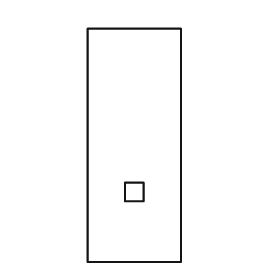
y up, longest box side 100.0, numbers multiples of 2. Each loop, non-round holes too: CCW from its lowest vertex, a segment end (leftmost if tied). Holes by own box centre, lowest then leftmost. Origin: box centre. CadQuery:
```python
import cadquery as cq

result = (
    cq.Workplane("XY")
    .moveTo(-20.0, -50.0)
    .lineTo(20.0, -50.0)
    .lineTo(20.0, 50.0)
    .lineTo(-20.0, 50.0)
    .close()
    .moveTo(-4.0, -24.0)
    .lineTo(4.0, -24.0)
    .lineTo(4.0, -16.0)
    .lineTo(-4.0, -16.0)
    .close()
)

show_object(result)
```